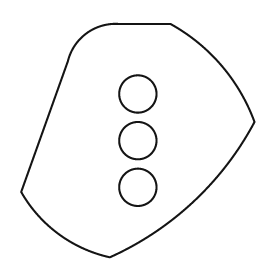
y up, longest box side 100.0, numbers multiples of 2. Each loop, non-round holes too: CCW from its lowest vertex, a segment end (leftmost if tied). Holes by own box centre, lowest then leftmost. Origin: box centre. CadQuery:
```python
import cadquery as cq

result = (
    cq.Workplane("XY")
    .moveTo(-12.0, -50.0)
    .threePointArc((24.0, -26.0), (50.0, 8.0))
    .threePointArc((36.0, 32.0), (14.0, 50.0))
    .lineTo(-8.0, 50.0)
    .threePointArc((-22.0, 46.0), (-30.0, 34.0))
    .lineTo(-50.0, -22.0)
    .threePointArc((-34.0, -40.0), (-12.0, -50.0))
    .close()
    .moveTo(0.0, -20.0)
    .circle(8.0)
    .moveTo(0.0, 0.0)
    .circle(8.0)
    .moveTo(0.0, 20.0)
    .circle(8.0)
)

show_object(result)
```